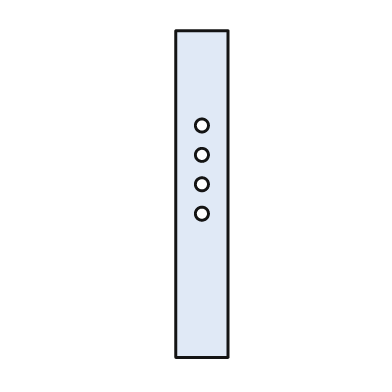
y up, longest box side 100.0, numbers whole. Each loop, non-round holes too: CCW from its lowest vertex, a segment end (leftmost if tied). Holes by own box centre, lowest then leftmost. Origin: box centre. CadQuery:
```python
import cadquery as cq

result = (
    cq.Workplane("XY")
    .moveTo(-8.0, -50.0)
    .lineTo(8.0, -50.0)
    .lineTo(8.0, 50.0)
    .lineTo(-8.0, 50.0)
    .close()
    .moveTo(0.0, -6.0)
    .circle(2.0)
    .moveTo(0.0, 3.0)
    .circle(2.0)
    .moveTo(0.0, 12.0)
    .circle(2.0)
    .moveTo(0.0, 21.0)
    .circle(2.0)
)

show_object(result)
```